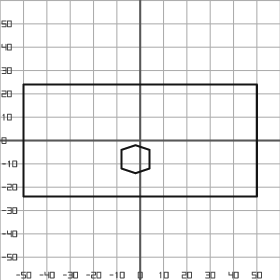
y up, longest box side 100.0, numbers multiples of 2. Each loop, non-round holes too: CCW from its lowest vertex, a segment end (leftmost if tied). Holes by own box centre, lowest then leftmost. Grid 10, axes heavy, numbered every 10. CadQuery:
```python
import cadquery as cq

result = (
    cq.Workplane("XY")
    .moveTo(-50.0, -24.0)
    .lineTo(50.0, -24.0)
    .lineTo(50.0, 24.0)
    .lineTo(-50.0, 24.0)
    .close()
    .moveTo(-2.0, -14.0)
    .lineTo(4.0, -12.0)
    .lineTo(4.0, -4.0)
    .lineTo(-2.0, -2.0)
    .lineTo(-8.0, -4.0)
    .lineTo(-8.0, -12.0)
    .close()
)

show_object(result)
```